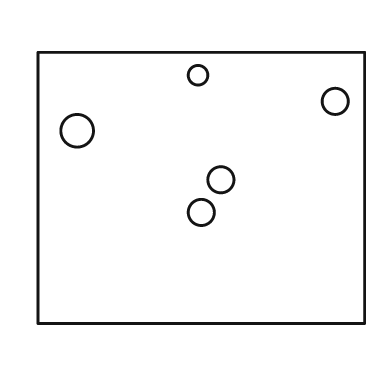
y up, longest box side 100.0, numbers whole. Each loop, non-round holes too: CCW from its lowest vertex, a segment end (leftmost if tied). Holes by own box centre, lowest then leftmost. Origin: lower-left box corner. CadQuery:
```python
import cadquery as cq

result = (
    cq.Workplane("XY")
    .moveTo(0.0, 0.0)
    .lineTo(100.0, 0.0)
    .lineTo(100.0, 83.0)
    .lineTo(0.0, 83.0)
    .close()
    .moveTo(50.0, 34.0)
    .circle(4.0)
    .moveTo(56.0, 44.0)
    .circle(4.0)
    .moveTo(12.0, 59.0)
    .circle(5.0)
    .moveTo(91.0, 68.0)
    .circle(4.0)
    .moveTo(49.0, 76.0)
    .circle(3.0)
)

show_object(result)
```